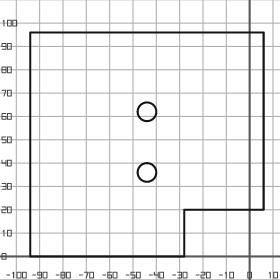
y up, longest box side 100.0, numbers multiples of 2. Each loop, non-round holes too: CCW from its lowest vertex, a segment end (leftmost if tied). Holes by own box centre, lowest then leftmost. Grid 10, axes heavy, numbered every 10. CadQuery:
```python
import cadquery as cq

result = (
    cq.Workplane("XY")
    .moveTo(-94.0, 0.0)
    .lineTo(-28.0, 0.0)
    .lineTo(-28.0, 20.0)
    .lineTo(6.0, 20.0)
    .lineTo(6.0, 96.0)
    .lineTo(-94.0, 96.0)
    .close()
    .moveTo(-44.0, 36.0)
    .circle(4.0)
    .moveTo(-44.0, 62.0)
    .circle(4.0)
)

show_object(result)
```